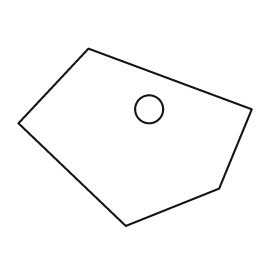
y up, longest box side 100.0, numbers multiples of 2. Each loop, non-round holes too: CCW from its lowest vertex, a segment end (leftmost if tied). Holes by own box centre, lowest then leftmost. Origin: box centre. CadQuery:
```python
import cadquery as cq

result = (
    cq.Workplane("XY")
    .moveTo(-4.0, -38.0)
    .lineTo(36.0, -22.0)
    .lineTo(50.0, 12.0)
    .lineTo(-20.0, 38.0)
    .lineTo(-50.0, 6.0)
    .close()
    .moveTo(6.0, 12.0)
    .circle(6.0)
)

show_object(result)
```